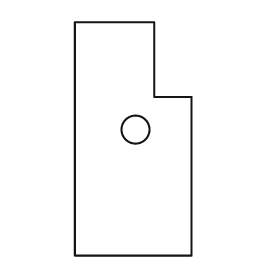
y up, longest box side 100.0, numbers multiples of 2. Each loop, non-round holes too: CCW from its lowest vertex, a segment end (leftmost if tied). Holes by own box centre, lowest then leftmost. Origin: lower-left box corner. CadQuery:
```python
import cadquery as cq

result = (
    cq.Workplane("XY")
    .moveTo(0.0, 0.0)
    .lineTo(50.0, 0.0)
    .lineTo(50.0, 68.0)
    .lineTo(34.0, 68.0)
    .lineTo(34.0, 100.0)
    .lineTo(0.0, 100.0)
    .close()
    .moveTo(26.0, 54.0)
    .circle(6.0)
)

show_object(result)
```